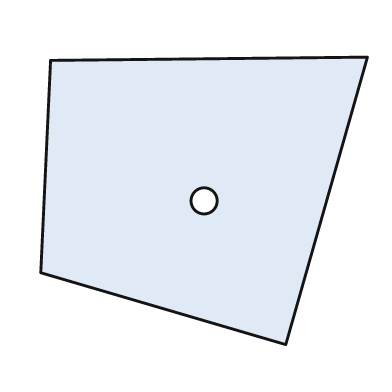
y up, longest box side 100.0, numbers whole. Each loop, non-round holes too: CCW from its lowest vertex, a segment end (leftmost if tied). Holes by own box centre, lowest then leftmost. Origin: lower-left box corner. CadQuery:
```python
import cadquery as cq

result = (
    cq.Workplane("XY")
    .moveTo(75.0, 0.0)
    .lineTo(100.0, 88.0)
    .lineTo(3.0, 87.0)
    .lineTo(0.0, 22.0)
    .close()
    .moveTo(50.0, 44.0)
    .circle(4.0)
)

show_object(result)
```